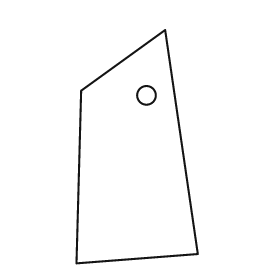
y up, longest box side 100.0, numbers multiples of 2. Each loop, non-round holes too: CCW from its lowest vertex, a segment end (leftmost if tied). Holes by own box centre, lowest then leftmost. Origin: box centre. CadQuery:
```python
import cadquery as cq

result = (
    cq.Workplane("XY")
    .moveTo(-26.0, -50.0)
    .lineTo(26.0, -46.0)
    .lineTo(12.0, 50.0)
    .lineTo(-24.0, 24.0)
    .close()
    .moveTo(4.0, 22.0)
    .circle(4.0)
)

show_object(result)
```